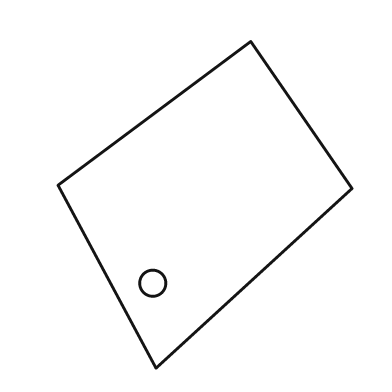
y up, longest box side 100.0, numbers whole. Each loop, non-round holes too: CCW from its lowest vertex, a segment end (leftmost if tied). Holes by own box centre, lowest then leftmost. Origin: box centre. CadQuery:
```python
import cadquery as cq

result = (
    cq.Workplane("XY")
    .moveTo(-15.0, -50.0)
    .lineTo(45.0, 5.0)
    .lineTo(14.0, 50.0)
    .lineTo(-45.0, 6.0)
    .close()
    .moveTo(-16.0, -24.0)
    .circle(4.0)
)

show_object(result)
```